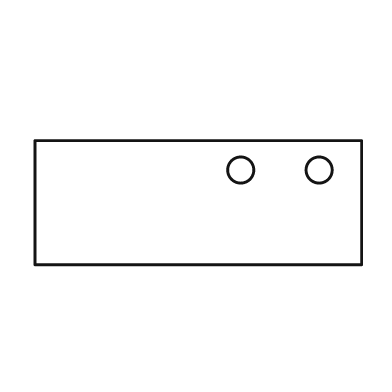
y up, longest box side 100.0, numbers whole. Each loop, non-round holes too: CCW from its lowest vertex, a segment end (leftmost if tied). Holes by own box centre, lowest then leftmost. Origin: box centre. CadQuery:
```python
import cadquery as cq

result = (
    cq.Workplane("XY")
    .moveTo(-50.0, -19.0)
    .lineTo(50.0, -19.0)
    .lineTo(50.0, 19.0)
    .lineTo(-50.0, 19.0)
    .close()
    .moveTo(13.0, 10.0)
    .circle(4.0)
    .moveTo(37.0, 10.0)
    .circle(4.0)
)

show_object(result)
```